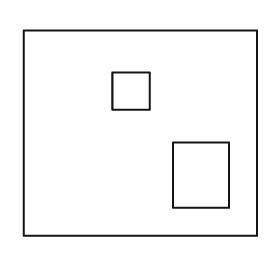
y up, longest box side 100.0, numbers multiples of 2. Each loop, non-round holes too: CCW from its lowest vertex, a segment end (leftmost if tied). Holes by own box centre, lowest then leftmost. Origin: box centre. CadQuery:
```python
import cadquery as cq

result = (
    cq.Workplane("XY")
    .moveTo(-50.0, -44.0)
    .lineTo(50.0, -44.0)
    .lineTo(50.0, 44.0)
    .lineTo(-50.0, 44.0)
    .close()
    .moveTo(14.0, -32.0)
    .lineTo(38.0, -32.0)
    .lineTo(38.0, -4.0)
    .lineTo(14.0, -4.0)
    .close()
    .moveTo(-12.0, 10.0)
    .lineTo(4.0, 10.0)
    .lineTo(4.0, 26.0)
    .lineTo(-12.0, 26.0)
    .close()
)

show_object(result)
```